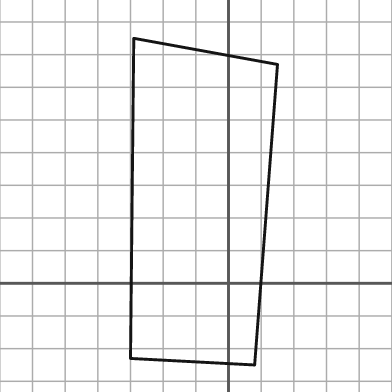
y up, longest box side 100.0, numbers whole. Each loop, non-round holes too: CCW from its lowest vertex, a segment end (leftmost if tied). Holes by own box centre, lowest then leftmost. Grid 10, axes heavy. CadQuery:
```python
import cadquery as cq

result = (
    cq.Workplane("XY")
    .moveTo(8.0, -25.0)
    .lineTo(15.0, 67.0)
    .lineTo(-29.0, 75.0)
    .lineTo(-30.0, -23.0)
    .close()
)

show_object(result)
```